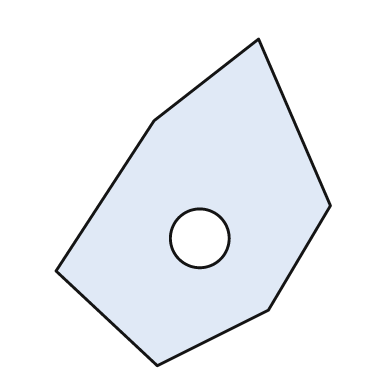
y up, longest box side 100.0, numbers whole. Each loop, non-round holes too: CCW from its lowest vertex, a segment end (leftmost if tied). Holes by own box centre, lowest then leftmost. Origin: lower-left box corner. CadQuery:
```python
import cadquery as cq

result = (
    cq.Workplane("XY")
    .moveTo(31.0, 0.0)
    .lineTo(65.0, 17.0)
    .lineTo(84.0, 49.0)
    .lineTo(62.0, 100.0)
    .lineTo(30.0, 75.0)
    .lineTo(0.0, 29.0)
    .close()
    .moveTo(44.0, 39.0)
    .circle(9.0)
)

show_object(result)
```